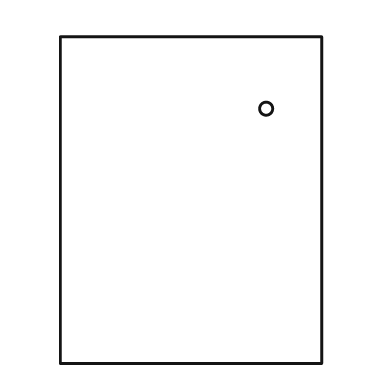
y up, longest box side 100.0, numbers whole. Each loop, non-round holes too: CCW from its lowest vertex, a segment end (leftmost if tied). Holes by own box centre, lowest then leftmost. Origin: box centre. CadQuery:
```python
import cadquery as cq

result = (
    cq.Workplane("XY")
    .moveTo(-40.0, -50.0)
    .lineTo(40.0, -50.0)
    .lineTo(40.0, 50.0)
    .lineTo(-40.0, 50.0)
    .close()
    .moveTo(23.0, 28.0)
    .circle(2.0)
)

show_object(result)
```